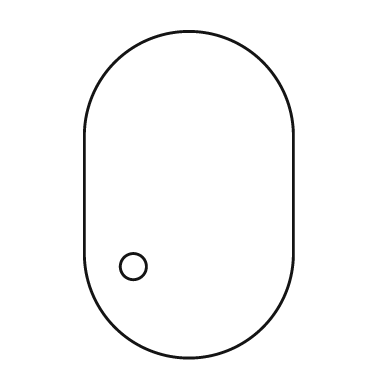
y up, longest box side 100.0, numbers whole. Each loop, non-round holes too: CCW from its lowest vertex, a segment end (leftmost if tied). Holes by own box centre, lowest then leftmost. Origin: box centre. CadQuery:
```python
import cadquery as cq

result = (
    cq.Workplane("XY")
    .moveTo(-32.0, -18.0)
    .threePointArc((0.0, -50.0), (32.0, -18.0))
    .lineTo(32.0, 18.0)
    .threePointArc((0.0, 50.0), (-32.0, 18.0))
    .close()
    .moveTo(-17.0, -22.0)
    .circle(4.0)
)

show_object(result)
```